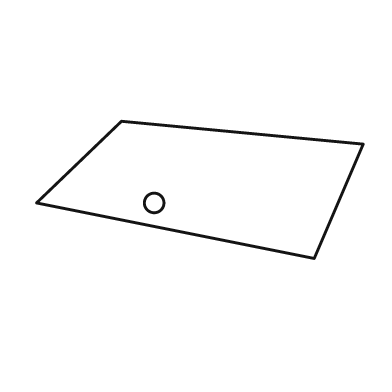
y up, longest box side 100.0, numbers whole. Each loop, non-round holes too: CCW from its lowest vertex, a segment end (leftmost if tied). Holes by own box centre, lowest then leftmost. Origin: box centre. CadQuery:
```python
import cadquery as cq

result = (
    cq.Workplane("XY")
    .moveTo(35.0, -21.0)
    .lineTo(50.0, 14.0)
    .lineTo(-24.0, 21.0)
    .lineTo(-50.0, -4.0)
    .close()
    .moveTo(-14.0, -4.0)
    .circle(3.0)
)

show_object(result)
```